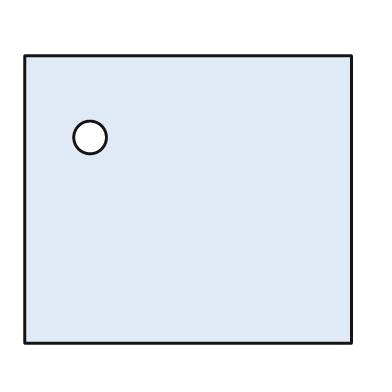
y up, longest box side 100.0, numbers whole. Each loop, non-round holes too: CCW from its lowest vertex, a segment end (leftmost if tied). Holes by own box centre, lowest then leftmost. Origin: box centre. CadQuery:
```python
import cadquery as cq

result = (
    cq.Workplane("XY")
    .moveTo(-50.0, -44.0)
    .lineTo(50.0, -44.0)
    .lineTo(50.0, 44.0)
    .lineTo(-50.0, 44.0)
    .close()
    .moveTo(-30.0, 19.0)
    .circle(5.0)
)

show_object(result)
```